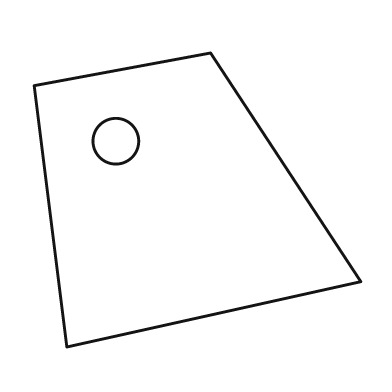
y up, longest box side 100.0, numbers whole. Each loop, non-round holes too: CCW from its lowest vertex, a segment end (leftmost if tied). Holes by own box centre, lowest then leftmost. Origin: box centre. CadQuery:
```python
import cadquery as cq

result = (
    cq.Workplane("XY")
    .moveTo(-40.0, -45.0)
    .lineTo(50.0, -25.0)
    .lineTo(4.0, 45.0)
    .lineTo(-50.0, 35.0)
    .close()
    .moveTo(-25.0, 18.0)
    .circle(7.0)
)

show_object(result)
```